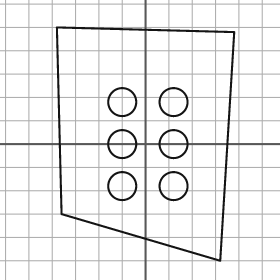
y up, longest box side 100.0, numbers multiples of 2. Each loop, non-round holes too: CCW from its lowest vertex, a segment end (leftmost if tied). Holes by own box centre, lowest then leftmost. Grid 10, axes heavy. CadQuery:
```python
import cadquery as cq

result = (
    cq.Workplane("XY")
    .moveTo(32.0, -50.0)
    .lineTo(38.0, 48.0)
    .lineTo(-38.0, 50.0)
    .lineTo(-36.0, -30.0)
    .close()
    .moveTo(-10.0, -18.0)
    .circle(6.0)
    .moveTo(12.0, -18.0)
    .circle(6.0)
    .moveTo(-10.0, 0.0)
    .circle(6.0)
    .moveTo(12.0, 0.0)
    .circle(6.0)
    .moveTo(-10.0, 18.0)
    .circle(6.0)
    .moveTo(12.0, 18.0)
    .circle(6.0)
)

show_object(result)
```